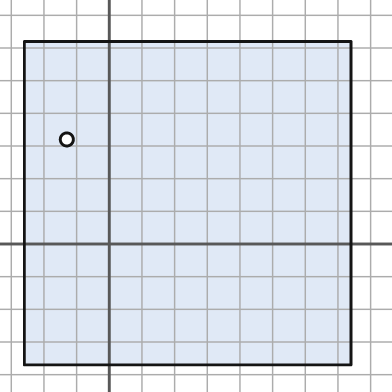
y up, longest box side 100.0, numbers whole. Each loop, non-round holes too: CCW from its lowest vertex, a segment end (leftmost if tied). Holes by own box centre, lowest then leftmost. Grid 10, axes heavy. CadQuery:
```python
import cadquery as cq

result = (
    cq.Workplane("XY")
    .moveTo(-26.0, -37.0)
    .lineTo(74.0, -37.0)
    .lineTo(74.0, 62.0)
    .lineTo(-26.0, 62.0)
    .close()
    .moveTo(-13.0, 32.0)
    .circle(2.0)
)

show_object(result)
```